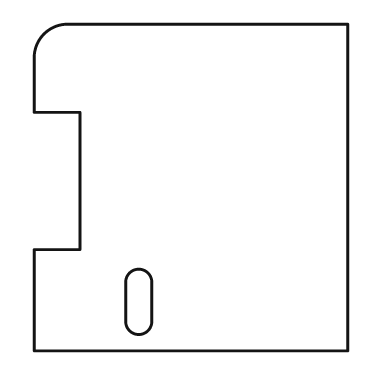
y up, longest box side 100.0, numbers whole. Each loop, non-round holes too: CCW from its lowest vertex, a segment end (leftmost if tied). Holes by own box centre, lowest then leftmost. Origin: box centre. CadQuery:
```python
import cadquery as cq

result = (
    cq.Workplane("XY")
    .moveTo(-48.0, -50.0)
    .lineTo(48.0, -50.0)
    .lineTo(48.0, 50.0)
    .lineTo(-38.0, 50.0)
    .threePointArc((-45.0, 47.0), (-48.0, 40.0))
    .lineTo(-48.0, 23.0)
    .lineTo(-34.0, 23.0)
    .lineTo(-34.0, -19.0)
    .lineTo(-48.0, -19.0)
    .close()
    .moveTo(-20.0, -41.0)
    .threePointArc((-16.0, -45.0), (-12.0, -41.0))
    .lineTo(-12.0, -29.0)
    .threePointArc((-16.0, -25.0), (-20.0, -29.0))
    .close()
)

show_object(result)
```